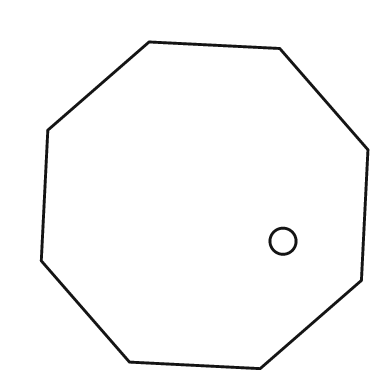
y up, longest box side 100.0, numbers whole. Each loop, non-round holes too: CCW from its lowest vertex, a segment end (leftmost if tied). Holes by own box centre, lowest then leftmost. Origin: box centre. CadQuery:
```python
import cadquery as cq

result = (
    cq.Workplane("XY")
    .moveTo(17.0, -50.0)
    .lineTo(48.0, -23.0)
    .lineTo(50.0, 17.0)
    .lineTo(23.0, 48.0)
    .lineTo(-17.0, 50.0)
    .lineTo(-48.0, 23.0)
    .lineTo(-50.0, -17.0)
    .lineTo(-23.0, -48.0)
    .close()
    .moveTo(24.0, -11.0)
    .circle(4.0)
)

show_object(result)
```